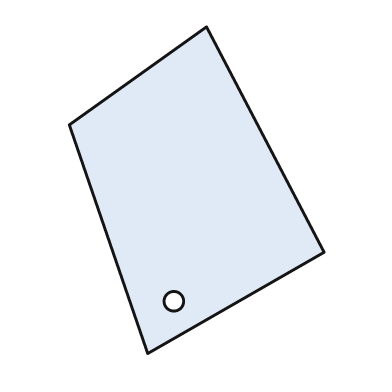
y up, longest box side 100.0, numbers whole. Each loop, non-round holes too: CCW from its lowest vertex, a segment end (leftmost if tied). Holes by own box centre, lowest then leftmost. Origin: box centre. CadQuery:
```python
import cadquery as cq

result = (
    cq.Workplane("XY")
    .moveTo(-15.0, -50.0)
    .lineTo(39.0, -19.0)
    .lineTo(3.0, 50.0)
    .lineTo(-39.0, 20.0)
    .close()
    .moveTo(-7.0, -34.0)
    .circle(3.0)
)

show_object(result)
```